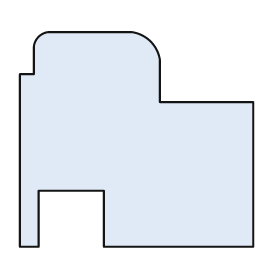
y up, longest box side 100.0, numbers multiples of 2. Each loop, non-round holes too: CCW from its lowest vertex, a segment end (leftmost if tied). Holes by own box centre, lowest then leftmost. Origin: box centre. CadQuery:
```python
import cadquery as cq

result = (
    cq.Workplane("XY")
    .moveTo(-50.0, -46.0)
    .lineTo(-42.0, -46.0)
    .lineTo(-42.0, -22.0)
    .lineTo(-14.0, -22.0)
    .lineTo(-14.0, -46.0)
    .lineTo(50.0, -46.0)
    .lineTo(50.0, 16.0)
    .lineTo(10.0, 16.0)
    .lineTo(10.0, 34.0)
    .threePointArc((6.0, 42.0), (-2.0, 46.0))
    .lineTo(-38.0, 46.0)
    .threePointArc((-42.0, 44.0), (-44.0, 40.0))
    .lineTo(-44.0, 28.0)
    .lineTo(-50.0, 28.0)
    .close()
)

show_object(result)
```